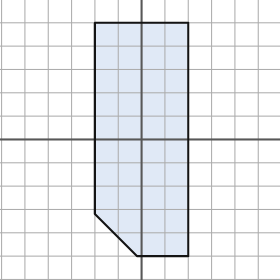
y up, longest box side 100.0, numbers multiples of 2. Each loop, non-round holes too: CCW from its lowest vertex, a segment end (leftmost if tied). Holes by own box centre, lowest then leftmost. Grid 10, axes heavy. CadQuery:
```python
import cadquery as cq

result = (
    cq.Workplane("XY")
    .moveTo(-2.0, -50.0)
    .lineTo(20.0, -50.0)
    .lineTo(20.0, 50.0)
    .lineTo(-20.0, 50.0)
    .lineTo(-20.0, -32.0)
    .close()
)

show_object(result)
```